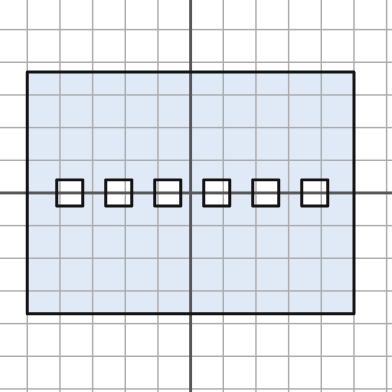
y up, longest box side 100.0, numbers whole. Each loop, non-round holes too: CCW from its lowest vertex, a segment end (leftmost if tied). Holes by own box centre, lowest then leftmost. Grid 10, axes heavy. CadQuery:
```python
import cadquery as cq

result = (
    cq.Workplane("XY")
    .moveTo(-50.0, -37.0)
    .lineTo(50.0, -37.0)
    .lineTo(50.0, 37.0)
    .lineTo(-50.0, 37.0)
    .close()
    .moveTo(-41.0, -4.0)
    .lineTo(-33.0, -4.0)
    .lineTo(-33.0, 4.0)
    .lineTo(-41.0, 4.0)
    .close()
    .moveTo(-26.0, -4.0)
    .lineTo(-18.0, -4.0)
    .lineTo(-18.0, 4.0)
    .lineTo(-26.0, 4.0)
    .close()
    .moveTo(-11.0, -4.0)
    .lineTo(-3.0, -4.0)
    .lineTo(-3.0, 4.0)
    .lineTo(-11.0, 4.0)
    .close()
    .moveTo(4.0, -4.0)
    .lineTo(12.0, -4.0)
    .lineTo(12.0, 4.0)
    .lineTo(4.0, 4.0)
    .close()
    .moveTo(19.0, -4.0)
    .lineTo(27.0, -4.0)
    .lineTo(27.0, 4.0)
    .lineTo(19.0, 4.0)
    .close()
    .moveTo(34.0, -4.0)
    .lineTo(42.0, -4.0)
    .lineTo(42.0, 4.0)
    .lineTo(34.0, 4.0)
    .close()
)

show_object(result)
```